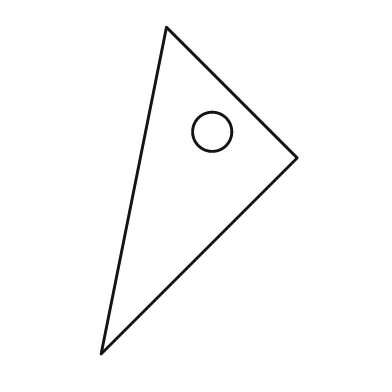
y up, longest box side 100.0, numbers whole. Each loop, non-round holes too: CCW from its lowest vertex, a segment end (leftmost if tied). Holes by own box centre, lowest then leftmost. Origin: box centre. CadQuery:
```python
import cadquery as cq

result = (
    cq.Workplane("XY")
    .moveTo(-30.0, -50.0)
    .lineTo(30.0, 10.0)
    .lineTo(-10.0, 50.0)
    .close()
    .moveTo(4.0, 18.0)
    .circle(6.0)
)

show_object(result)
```